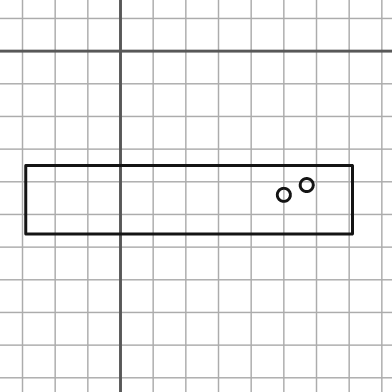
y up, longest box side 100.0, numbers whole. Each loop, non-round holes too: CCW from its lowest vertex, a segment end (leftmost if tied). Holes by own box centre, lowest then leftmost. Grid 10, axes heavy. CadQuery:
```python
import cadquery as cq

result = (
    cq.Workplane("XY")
    .moveTo(-29.0, -56.0)
    .lineTo(71.0, -56.0)
    .lineTo(71.0, -35.0)
    .lineTo(-29.0, -35.0)
    .close()
    .moveTo(50.0, -44.0)
    .circle(2.0)
    .moveTo(57.0, -41.0)
    .circle(2.0)
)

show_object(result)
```